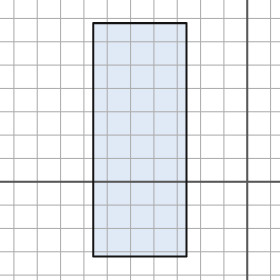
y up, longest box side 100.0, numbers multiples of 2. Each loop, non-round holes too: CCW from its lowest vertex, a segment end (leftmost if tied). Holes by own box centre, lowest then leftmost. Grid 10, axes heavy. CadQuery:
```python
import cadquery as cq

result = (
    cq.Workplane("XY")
    .moveTo(-66.0, -32.0)
    .lineTo(-26.0, -32.0)
    .lineTo(-26.0, 68.0)
    .lineTo(-66.0, 68.0)
    .close()
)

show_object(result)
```